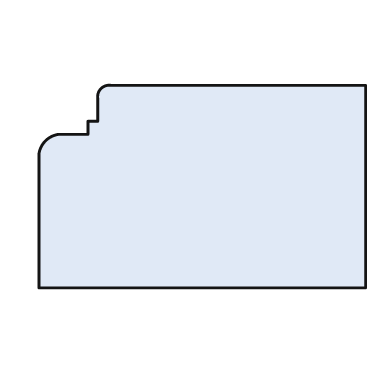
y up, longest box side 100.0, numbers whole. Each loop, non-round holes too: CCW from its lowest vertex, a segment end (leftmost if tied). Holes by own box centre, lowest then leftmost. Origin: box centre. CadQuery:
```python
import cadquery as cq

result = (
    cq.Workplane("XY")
    .moveTo(-50.0, -31.0)
    .lineTo(50.0, -31.0)
    .lineTo(50.0, 31.0)
    .lineTo(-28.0, 31.0)
    .threePointArc((-31.0, 30.0), (-32.0, 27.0))
    .lineTo(-32.0, 20.0)
    .lineTo(-35.0, 20.0)
    .lineTo(-35.0, 16.0)
    .lineTo(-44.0, 16.0)
    .threePointArc((-48.0, 14.0), (-50.0, 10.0))
    .close()
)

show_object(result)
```